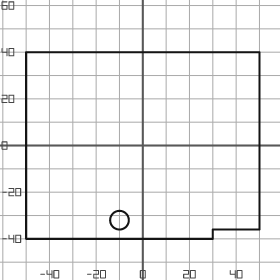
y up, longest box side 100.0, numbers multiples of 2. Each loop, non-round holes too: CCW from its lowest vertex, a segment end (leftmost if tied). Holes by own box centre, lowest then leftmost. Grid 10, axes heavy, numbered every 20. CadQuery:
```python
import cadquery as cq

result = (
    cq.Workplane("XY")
    .moveTo(-50.0, -40.0)
    .lineTo(30.0, -40.0)
    .lineTo(30.0, -36.0)
    .lineTo(50.0, -36.0)
    .lineTo(50.0, 40.0)
    .lineTo(-50.0, 40.0)
    .close()
    .moveTo(-10.0, -32.0)
    .circle(4.0)
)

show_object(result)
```